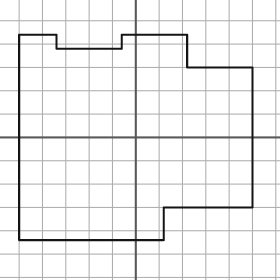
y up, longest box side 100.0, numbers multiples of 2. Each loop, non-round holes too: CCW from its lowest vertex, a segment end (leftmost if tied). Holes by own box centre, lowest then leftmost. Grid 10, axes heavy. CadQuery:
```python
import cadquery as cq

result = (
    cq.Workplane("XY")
    .moveTo(-50.0, -44.0)
    .lineTo(12.0, -44.0)
    .lineTo(12.0, -30.0)
    .lineTo(50.0, -30.0)
    .lineTo(50.0, 30.0)
    .lineTo(22.0, 30.0)
    .lineTo(22.0, 44.0)
    .lineTo(-6.0, 44.0)
    .lineTo(-6.0, 38.0)
    .lineTo(-34.0, 38.0)
    .lineTo(-34.0, 44.0)
    .lineTo(-50.0, 44.0)
    .close()
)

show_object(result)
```